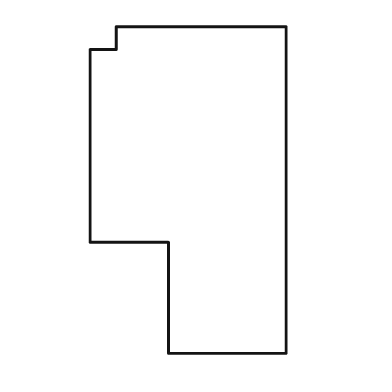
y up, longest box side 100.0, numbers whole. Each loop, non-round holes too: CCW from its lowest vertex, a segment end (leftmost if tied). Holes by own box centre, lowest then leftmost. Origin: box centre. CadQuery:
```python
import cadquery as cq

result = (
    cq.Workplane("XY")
    .moveTo(-6.0, -50.0)
    .lineTo(30.0, -50.0)
    .lineTo(30.0, 50.0)
    .lineTo(-22.0, 50.0)
    .lineTo(-22.0, 43.0)
    .lineTo(-30.0, 43.0)
    .lineTo(-30.0, -16.0)
    .lineTo(-6.0, -16.0)
    .close()
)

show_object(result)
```